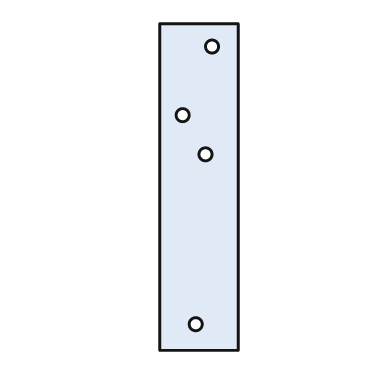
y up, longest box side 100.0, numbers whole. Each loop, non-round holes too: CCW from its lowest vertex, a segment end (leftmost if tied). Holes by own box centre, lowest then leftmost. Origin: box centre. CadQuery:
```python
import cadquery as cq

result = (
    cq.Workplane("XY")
    .moveTo(-12.0, -50.0)
    .lineTo(12.0, -50.0)
    .lineTo(12.0, 50.0)
    .lineTo(-12.0, 50.0)
    .close()
    .moveTo(-1.0, -42.0)
    .circle(2.0)
    .moveTo(2.0, 10.0)
    .circle(2.0)
    .moveTo(-5.0, 22.0)
    .circle(2.0)
    .moveTo(4.0, 43.0)
    .circle(2.0)
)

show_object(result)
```